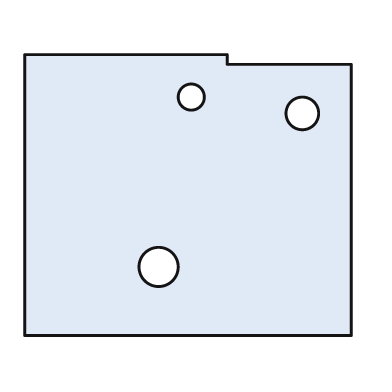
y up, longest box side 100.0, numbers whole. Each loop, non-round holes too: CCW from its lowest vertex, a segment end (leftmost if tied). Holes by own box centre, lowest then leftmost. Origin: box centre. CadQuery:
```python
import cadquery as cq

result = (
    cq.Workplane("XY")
    .moveTo(-50.0, -43.0)
    .lineTo(50.0, -43.0)
    .lineTo(50.0, 40.0)
    .lineTo(12.0, 40.0)
    .lineTo(12.0, 43.0)
    .lineTo(-50.0, 43.0)
    .close()
    .moveTo(-9.0, -22.0)
    .circle(6.0)
    .moveTo(35.0, 25.0)
    .circle(5.0)
    .moveTo(1.0, 30.0)
    .circle(4.0)
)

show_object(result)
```